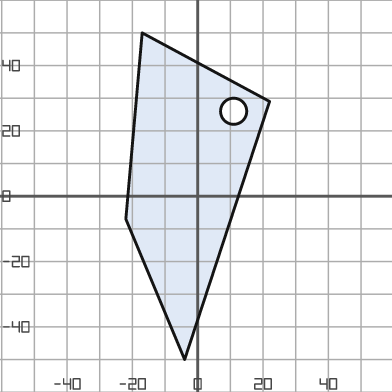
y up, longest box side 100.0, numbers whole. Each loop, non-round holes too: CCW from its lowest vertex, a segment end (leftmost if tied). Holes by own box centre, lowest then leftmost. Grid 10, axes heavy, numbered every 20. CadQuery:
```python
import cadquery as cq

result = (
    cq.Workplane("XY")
    .moveTo(-4.0, -50.0)
    .lineTo(22.0, 29.0)
    .lineTo(-17.0, 50.0)
    .lineTo(-22.0, -7.0)
    .close()
    .moveTo(11.0, 26.0)
    .circle(4.0)
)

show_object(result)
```